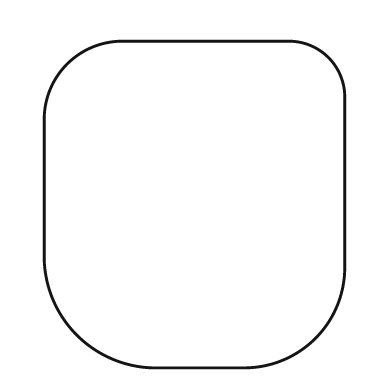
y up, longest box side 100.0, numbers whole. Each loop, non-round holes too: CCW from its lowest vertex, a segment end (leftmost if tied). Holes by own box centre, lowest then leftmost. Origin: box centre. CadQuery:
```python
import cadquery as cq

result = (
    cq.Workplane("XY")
    .moveTo(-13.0, -50.0)
    .lineTo(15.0, -50.0)
    .threePointArc((37.0, -41.0), (46.0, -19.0))
    .lineTo(46.0, 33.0)
    .threePointArc((41.0, 45.0), (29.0, 50.0))
    .lineTo(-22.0, 50.0)
    .threePointArc((-39.0, 43.0), (-46.0, 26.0))
    .lineTo(-46.0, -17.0)
    .threePointArc((-36.0, -40.0), (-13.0, -50.0))
    .close()
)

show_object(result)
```